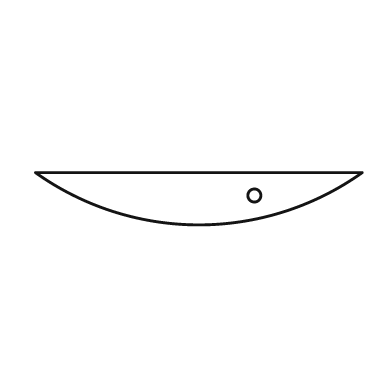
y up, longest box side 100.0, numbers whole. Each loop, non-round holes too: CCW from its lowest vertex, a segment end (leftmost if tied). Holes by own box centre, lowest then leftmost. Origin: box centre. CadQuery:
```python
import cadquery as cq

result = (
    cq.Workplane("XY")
    .moveTo(-50.0, 8.0)
    .threePointArc((0.0, -8.0), (50.0, 8.0))
    .close()
    .moveTo(17.0, 1.0)
    .circle(2.0)
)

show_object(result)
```